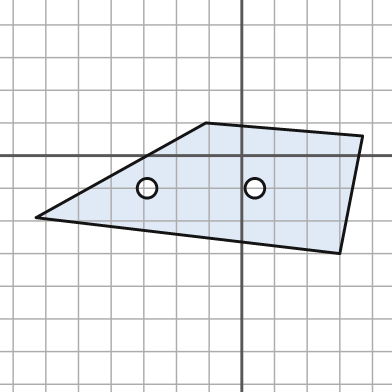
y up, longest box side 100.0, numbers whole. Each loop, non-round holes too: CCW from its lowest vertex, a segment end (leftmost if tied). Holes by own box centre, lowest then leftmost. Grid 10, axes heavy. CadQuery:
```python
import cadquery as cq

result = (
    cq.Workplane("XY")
    .moveTo(30.0, -30.0)
    .lineTo(37.0, 6.0)
    .lineTo(-11.0, 10.0)
    .lineTo(-63.0, -19.0)
    .close()
    .moveTo(-29.0, -10.0)
    .circle(3.0)
    .moveTo(4.0, -10.0)
    .circle(3.0)
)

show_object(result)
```